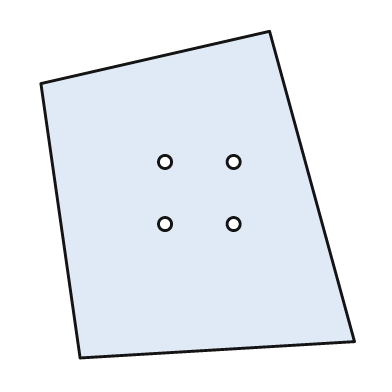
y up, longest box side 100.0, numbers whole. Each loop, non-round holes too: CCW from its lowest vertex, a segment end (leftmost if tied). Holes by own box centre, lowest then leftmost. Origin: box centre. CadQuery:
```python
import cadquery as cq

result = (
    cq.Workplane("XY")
    .moveTo(-36.0, -50.0)
    .lineTo(48.0, -45.0)
    .lineTo(22.0, 50.0)
    .lineTo(-48.0, 34.0)
    .close()
    .moveTo(-10.0, -9.0)
    .circle(2.0)
    .moveTo(11.0, -9.0)
    .circle(2.0)
    .moveTo(-10.0, 10.0)
    .circle(2.0)
    .moveTo(11.0, 10.0)
    .circle(2.0)
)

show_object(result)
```